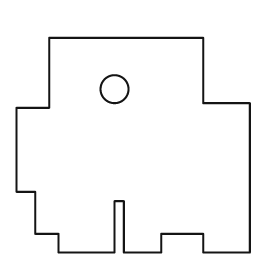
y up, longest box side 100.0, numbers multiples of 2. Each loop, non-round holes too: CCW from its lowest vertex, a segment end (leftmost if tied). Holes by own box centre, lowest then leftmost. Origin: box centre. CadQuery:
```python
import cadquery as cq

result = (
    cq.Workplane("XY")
    .moveTo(-32.0, -46.0)
    .lineTo(-8.0, -46.0)
    .lineTo(-8.0, -24.0)
    .lineTo(-4.0, -24.0)
    .lineTo(-4.0, -46.0)
    .lineTo(12.0, -46.0)
    .lineTo(12.0, -38.0)
    .lineTo(30.0, -38.0)
    .lineTo(30.0, -46.0)
    .lineTo(50.0, -46.0)
    .lineTo(50.0, 18.0)
    .lineTo(30.0, 18.0)
    .lineTo(30.0, 46.0)
    .lineTo(-36.0, 46.0)
    .lineTo(-36.0, 16.0)
    .lineTo(-50.0, 16.0)
    .lineTo(-50.0, -20.0)
    .lineTo(-42.0, -20.0)
    .lineTo(-42.0, -38.0)
    .lineTo(-32.0, -38.0)
    .close()
    .moveTo(-8.0, 24.0)
    .circle(6.0)
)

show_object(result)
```